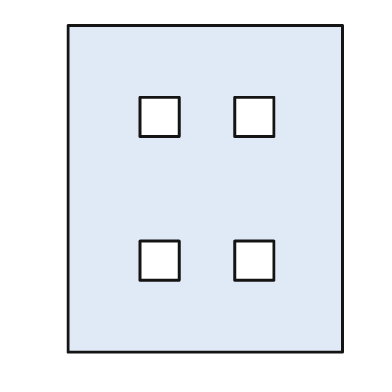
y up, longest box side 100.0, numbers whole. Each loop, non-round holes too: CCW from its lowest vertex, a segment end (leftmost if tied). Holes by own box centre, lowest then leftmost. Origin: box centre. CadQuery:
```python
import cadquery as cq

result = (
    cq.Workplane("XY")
    .moveTo(-42.0, -50.0)
    .lineTo(42.0, -50.0)
    .lineTo(42.0, 50.0)
    .lineTo(-42.0, 50.0)
    .close()
    .moveTo(-20.0, -28.0)
    .lineTo(-8.0, -28.0)
    .lineTo(-8.0, -16.0)
    .lineTo(-20.0, -16.0)
    .close()
    .moveTo(9.0, -28.0)
    .lineTo(21.0, -28.0)
    .lineTo(21.0, -16.0)
    .lineTo(9.0, -16.0)
    .close()
    .moveTo(-20.0, 16.0)
    .lineTo(-8.0, 16.0)
    .lineTo(-8.0, 28.0)
    .lineTo(-20.0, 28.0)
    .close()
    .moveTo(9.0, 16.0)
    .lineTo(21.0, 16.0)
    .lineTo(21.0, 28.0)
    .lineTo(9.0, 28.0)
    .close()
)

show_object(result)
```